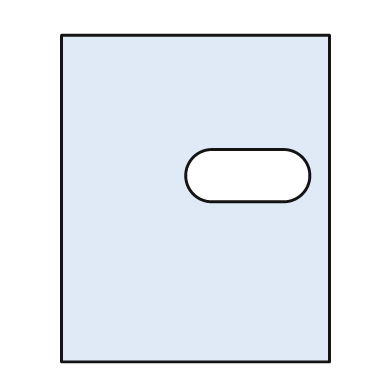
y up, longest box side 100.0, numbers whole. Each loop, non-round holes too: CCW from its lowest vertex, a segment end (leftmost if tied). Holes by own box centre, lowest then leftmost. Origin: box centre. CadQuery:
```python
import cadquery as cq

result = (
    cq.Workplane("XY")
    .moveTo(-41.0, -50.0)
    .lineTo(41.0, -50.0)
    .lineTo(41.0, 50.0)
    .lineTo(-41.0, 50.0)
    .close()
    .moveTo(5.0, -1.0)
    .lineTo(27.0, -1.0)
    .threePointArc((35.0, 7.0), (27.0, 15.0))
    .lineTo(5.0, 15.0)
    .threePointArc((-3.0, 7.0), (5.0, -1.0))
    .close()
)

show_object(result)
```